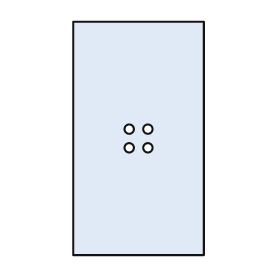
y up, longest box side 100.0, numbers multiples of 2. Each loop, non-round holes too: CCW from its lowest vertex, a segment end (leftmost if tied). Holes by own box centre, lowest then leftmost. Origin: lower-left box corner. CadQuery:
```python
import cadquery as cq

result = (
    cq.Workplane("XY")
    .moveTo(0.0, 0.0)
    .lineTo(56.0, 0.0)
    .lineTo(56.0, 100.0)
    .lineTo(0.0, 100.0)
    .close()
    .moveTo(24.0, 46.0)
    .circle(2.0)
    .moveTo(32.0, 46.0)
    .circle(2.0)
    .moveTo(24.0, 54.0)
    .circle(2.0)
    .moveTo(32.0, 54.0)
    .circle(2.0)
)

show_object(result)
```